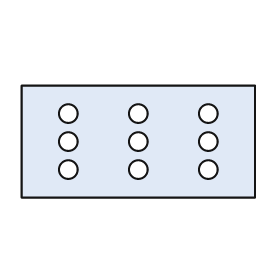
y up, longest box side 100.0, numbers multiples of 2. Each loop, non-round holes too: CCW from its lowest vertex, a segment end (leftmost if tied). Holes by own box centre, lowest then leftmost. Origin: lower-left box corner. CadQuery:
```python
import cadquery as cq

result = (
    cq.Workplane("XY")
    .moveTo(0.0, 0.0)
    .lineTo(100.0, 0.0)
    .lineTo(100.0, 48.0)
    .lineTo(0.0, 48.0)
    .close()
    .moveTo(20.0, 12.0)
    .circle(4.0)
    .moveTo(50.0, 12.0)
    .circle(4.0)
    .moveTo(80.0, 12.0)
    .circle(4.0)
    .moveTo(20.0, 24.0)
    .circle(4.0)
    .moveTo(50.0, 24.0)
    .circle(4.0)
    .moveTo(80.0, 24.0)
    .circle(4.0)
    .moveTo(20.0, 36.0)
    .circle(4.0)
    .moveTo(50.0, 36.0)
    .circle(4.0)
    .moveTo(80.0, 36.0)
    .circle(4.0)
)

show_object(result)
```